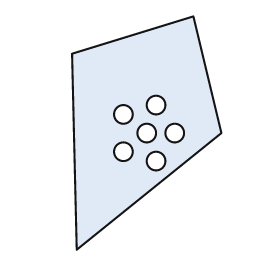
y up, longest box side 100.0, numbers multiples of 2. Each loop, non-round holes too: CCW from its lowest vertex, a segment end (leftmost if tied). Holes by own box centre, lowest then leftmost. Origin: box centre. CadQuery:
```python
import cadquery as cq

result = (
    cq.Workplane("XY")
    .moveTo(-30.0, -50.0)
    .lineTo(32.0, 0.0)
    .lineTo(20.0, 50.0)
    .lineTo(-32.0, 34.0)
    .close()
    .moveTo(4.0, -12.0)
    .circle(4.0)
    .moveTo(-10.0, -8.0)
    .circle(4.0)
    .moveTo(0.0, 0.0)
    .circle(4.0)
    .moveTo(12.0, 0.0)
    .circle(4.0)
    .moveTo(-10.0, 8.0)
    .circle(4.0)
    .moveTo(4.0, 12.0)
    .circle(4.0)
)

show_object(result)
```